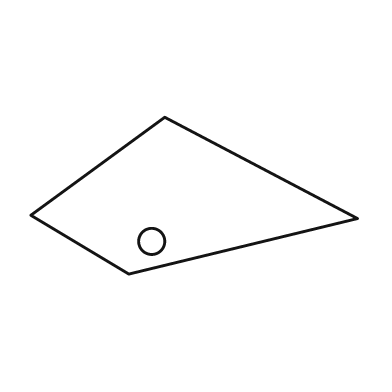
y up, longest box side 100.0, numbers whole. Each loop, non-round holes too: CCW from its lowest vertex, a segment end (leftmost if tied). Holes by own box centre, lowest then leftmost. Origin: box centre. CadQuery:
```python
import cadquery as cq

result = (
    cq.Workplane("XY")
    .moveTo(-20.0, -24.0)
    .lineTo(50.0, -7.0)
    .lineTo(-9.0, 24.0)
    .lineTo(-50.0, -6.0)
    .close()
    .moveTo(-13.0, -14.0)
    .circle(4.0)
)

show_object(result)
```